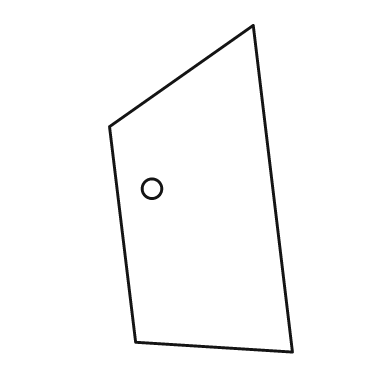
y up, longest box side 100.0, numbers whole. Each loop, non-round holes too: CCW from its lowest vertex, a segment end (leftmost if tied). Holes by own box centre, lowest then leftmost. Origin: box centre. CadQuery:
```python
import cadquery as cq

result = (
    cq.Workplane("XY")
    .moveTo(28.0, -50.0)
    .lineTo(16.0, 50.0)
    .lineTo(-28.0, 19.0)
    .lineTo(-20.0, -47.0)
    .close()
    .moveTo(-15.0, 0.0)
    .circle(3.0)
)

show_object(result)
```